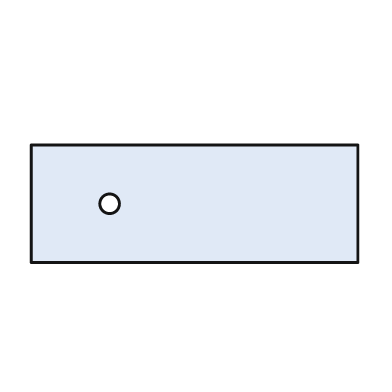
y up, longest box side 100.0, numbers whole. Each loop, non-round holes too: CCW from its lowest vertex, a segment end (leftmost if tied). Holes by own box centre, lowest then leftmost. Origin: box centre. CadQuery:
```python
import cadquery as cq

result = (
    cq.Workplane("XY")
    .moveTo(-50.0, -18.0)
    .lineTo(50.0, -18.0)
    .lineTo(50.0, 18.0)
    .lineTo(-50.0, 18.0)
    .close()
    .moveTo(-26.0, 0.0)
    .circle(3.0)
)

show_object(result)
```